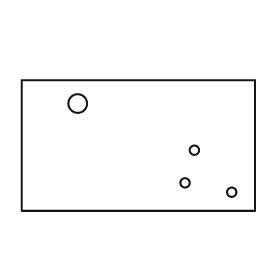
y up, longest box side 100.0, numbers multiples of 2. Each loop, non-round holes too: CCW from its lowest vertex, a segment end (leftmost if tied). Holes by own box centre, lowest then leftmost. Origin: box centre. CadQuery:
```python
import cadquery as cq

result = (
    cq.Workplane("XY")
    .moveTo(-50.0, -28.0)
    .lineTo(50.0, -28.0)
    .lineTo(50.0, 28.0)
    .lineTo(-50.0, 28.0)
    .close()
    .moveTo(40.0, -20.0)
    .circle(2.0)
    .moveTo(20.0, -16.0)
    .circle(2.0)
    .moveTo(24.0, -2.0)
    .circle(2.0)
    .moveTo(-26.0, 18.0)
    .circle(4.0)
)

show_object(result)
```